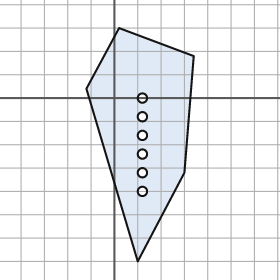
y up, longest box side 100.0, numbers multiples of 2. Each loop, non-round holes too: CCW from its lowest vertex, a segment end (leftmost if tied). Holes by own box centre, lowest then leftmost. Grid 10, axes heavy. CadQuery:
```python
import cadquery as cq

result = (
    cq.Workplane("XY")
    .moveTo(10.0, -70.0)
    .lineTo(30.0, -32.0)
    .lineTo(34.0, 18.0)
    .lineTo(2.0, 30.0)
    .lineTo(-12.0, 4.0)
    .close()
    .moveTo(12.0, -40.0)
    .circle(2.0)
    .moveTo(12.0, -32.0)
    .circle(2.0)
    .moveTo(12.0, -24.0)
    .circle(2.0)
    .moveTo(12.0, -16.0)
    .circle(2.0)
    .moveTo(12.0, -8.0)
    .circle(2.0)
    .moveTo(12.0, 0.0)
    .circle(2.0)
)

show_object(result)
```